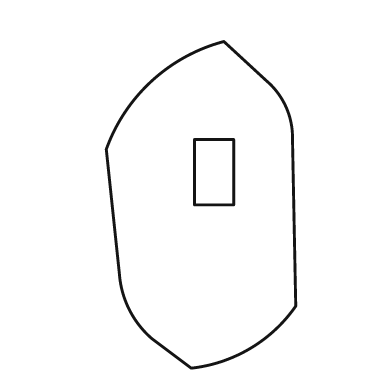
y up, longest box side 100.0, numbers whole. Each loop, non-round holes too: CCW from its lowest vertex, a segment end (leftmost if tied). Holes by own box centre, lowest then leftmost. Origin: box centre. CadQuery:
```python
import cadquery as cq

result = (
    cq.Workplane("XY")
    .moveTo(-3.0, -50.0)
    .threePointArc((15.0, -44.0), (29.0, -31.0))
    .lineTo(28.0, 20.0)
    .threePointArc((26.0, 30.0), (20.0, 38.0))
    .lineTo(7.0, 50.0)
    .threePointArc((-15.0, 38.0), (-29.0, 17.0))
    .lineTo(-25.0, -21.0)
    .threePointArc((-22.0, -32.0), (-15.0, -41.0))
    .close()
    .moveTo(-2.0, 0.0)
    .lineTo(10.0, 0.0)
    .lineTo(10.0, 20.0)
    .lineTo(-2.0, 20.0)
    .close()
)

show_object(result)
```